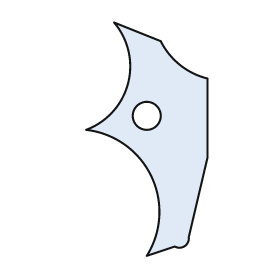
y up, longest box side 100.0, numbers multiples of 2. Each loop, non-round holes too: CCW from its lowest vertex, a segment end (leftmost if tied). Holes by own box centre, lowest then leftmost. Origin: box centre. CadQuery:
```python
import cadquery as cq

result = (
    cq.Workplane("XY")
    .moveTo(0.0, -50.0)
    .lineTo(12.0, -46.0)
    .threePointArc((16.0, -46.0), (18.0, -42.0))
    .lineTo(26.0, -8.0)
    .lineTo(26.0, 26.0)
    .threePointArc((14.0, 32.0), (6.0, 42.0))
    .lineTo(-14.0, 50.0)
    .threePointArc((-8.0, 24.0), (-26.0, 4.0))
    .threePointArc((2.0, -16.0), (0.0, -50.0))
    .close()
    .moveTo(0.0, 10.0)
    .circle(6.0)
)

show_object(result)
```